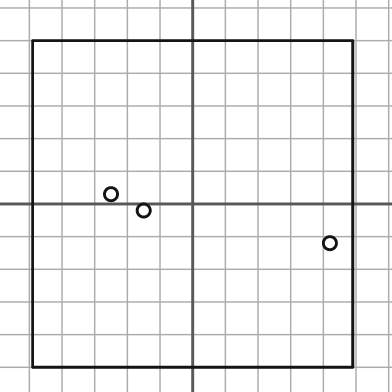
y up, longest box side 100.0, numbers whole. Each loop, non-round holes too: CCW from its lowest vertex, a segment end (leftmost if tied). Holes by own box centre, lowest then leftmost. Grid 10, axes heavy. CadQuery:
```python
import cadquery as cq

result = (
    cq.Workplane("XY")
    .moveTo(-49.0, -50.0)
    .lineTo(49.0, -50.0)
    .lineTo(49.0, 50.0)
    .lineTo(-49.0, 50.0)
    .close()
    .moveTo(42.0, -12.0)
    .circle(2.0)
    .moveTo(-15.0, -2.0)
    .circle(2.0)
    .moveTo(-25.0, 3.0)
    .circle(2.0)
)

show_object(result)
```